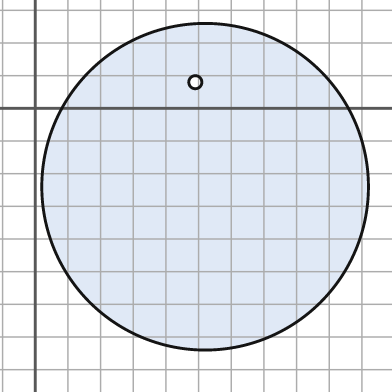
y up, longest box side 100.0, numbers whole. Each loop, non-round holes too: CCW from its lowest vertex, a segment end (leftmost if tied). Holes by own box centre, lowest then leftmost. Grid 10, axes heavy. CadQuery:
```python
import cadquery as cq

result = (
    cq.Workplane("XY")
    .moveTo(52.0, -24.0)
    .circle(50.0)
    .moveTo(49.0, 8.0)
    .circle(2.0)
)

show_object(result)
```